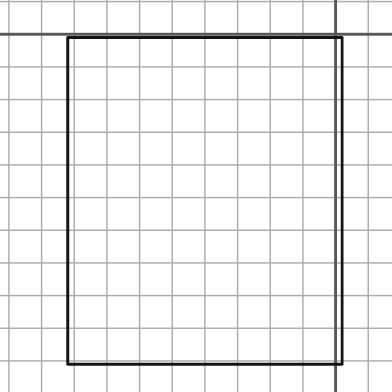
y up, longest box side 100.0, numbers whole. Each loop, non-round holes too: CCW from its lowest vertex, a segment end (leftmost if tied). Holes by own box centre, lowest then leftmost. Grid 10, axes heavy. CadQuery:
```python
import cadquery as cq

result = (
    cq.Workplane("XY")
    .moveTo(-82.0, -101.0)
    .lineTo(2.0, -101.0)
    .lineTo(2.0, -1.0)
    .lineTo(-82.0, -1.0)
    .close()
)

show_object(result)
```